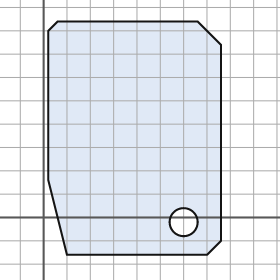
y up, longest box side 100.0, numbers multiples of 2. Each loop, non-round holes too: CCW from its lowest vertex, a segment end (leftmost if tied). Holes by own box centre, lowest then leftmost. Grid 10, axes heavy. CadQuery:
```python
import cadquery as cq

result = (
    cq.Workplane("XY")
    .moveTo(10.0, -16.0)
    .lineTo(70.0, -16.0)
    .lineTo(76.0, -10.0)
    .lineTo(76.0, 74.0)
    .lineTo(66.0, 84.0)
    .lineTo(6.0, 84.0)
    .lineTo(2.0, 80.0)
    .lineTo(2.0, 16.0)
    .close()
    .moveTo(60.0, -2.0)
    .circle(6.0)
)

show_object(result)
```